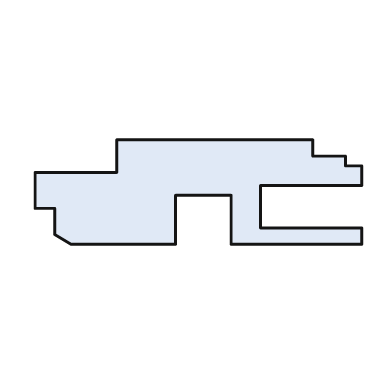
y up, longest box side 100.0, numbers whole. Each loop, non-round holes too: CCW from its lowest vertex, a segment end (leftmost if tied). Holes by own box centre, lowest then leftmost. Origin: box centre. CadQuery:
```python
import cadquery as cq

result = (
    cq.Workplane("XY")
    .moveTo(-39.0, -16.0)
    .lineTo(-7.0, -16.0)
    .lineTo(-7.0, -1.0)
    .lineTo(10.0, -1.0)
    .lineTo(10.0, -16.0)
    .lineTo(50.0, -16.0)
    .lineTo(50.0, -11.0)
    .lineTo(19.0, -11.0)
    .lineTo(19.0, 2.0)
    .lineTo(50.0, 2.0)
    .lineTo(50.0, 8.0)
    .lineTo(45.0, 8.0)
    .lineTo(45.0, 11.0)
    .lineTo(35.0, 11.0)
    .lineTo(35.0, 16.0)
    .lineTo(-25.0, 16.0)
    .lineTo(-25.0, 6.0)
    .lineTo(-50.0, 6.0)
    .lineTo(-50.0, -5.0)
    .lineTo(-44.0, -5.0)
    .lineTo(-44.0, -13.0)
    .close()
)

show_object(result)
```